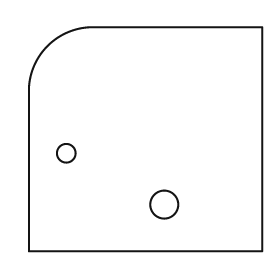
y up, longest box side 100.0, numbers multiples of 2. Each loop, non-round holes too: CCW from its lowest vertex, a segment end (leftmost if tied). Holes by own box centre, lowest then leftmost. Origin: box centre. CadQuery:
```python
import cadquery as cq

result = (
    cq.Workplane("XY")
    .moveTo(-50.0, -48.0)
    .lineTo(50.0, -48.0)
    .lineTo(50.0, 48.0)
    .lineTo(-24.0, 48.0)
    .threePointArc((-42.0, 40.0), (-50.0, 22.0))
    .close()
    .moveTo(8.0, -28.0)
    .circle(6.0)
    .moveTo(-34.0, -6.0)
    .circle(4.0)
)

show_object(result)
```